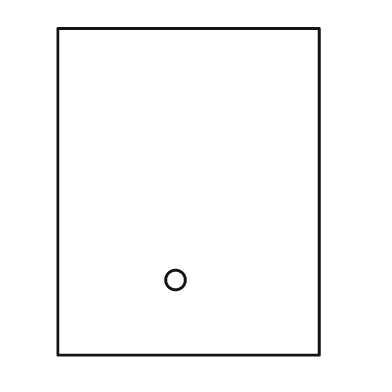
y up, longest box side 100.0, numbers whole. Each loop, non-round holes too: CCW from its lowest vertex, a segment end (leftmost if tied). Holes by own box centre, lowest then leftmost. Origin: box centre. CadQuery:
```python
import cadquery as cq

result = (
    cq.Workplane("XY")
    .moveTo(-40.0, -50.0)
    .lineTo(40.0, -50.0)
    .lineTo(40.0, 50.0)
    .lineTo(-40.0, 50.0)
    .close()
    .moveTo(-4.0, -27.0)
    .circle(3.0)
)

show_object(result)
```